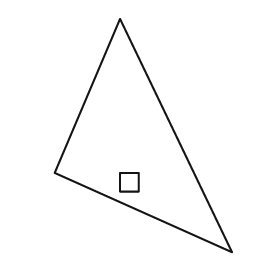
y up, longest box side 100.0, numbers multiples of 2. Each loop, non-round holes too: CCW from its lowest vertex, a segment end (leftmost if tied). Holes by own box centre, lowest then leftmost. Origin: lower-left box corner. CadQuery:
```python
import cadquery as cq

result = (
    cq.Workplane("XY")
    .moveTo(76.0, 0.0)
    .lineTo(28.0, 100.0)
    .lineTo(0.0, 34.0)
    .close()
    .moveTo(28.0, 26.0)
    .lineTo(36.0, 26.0)
    .lineTo(36.0, 34.0)
    .lineTo(28.0, 34.0)
    .close()
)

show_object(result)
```